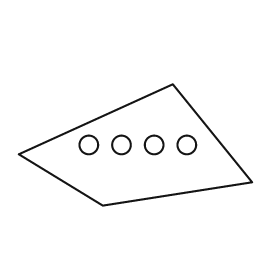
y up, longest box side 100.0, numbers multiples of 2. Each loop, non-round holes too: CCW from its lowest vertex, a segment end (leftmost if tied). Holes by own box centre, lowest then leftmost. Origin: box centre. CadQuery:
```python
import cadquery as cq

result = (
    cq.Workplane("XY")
    .moveTo(-14.0, -26.0)
    .lineTo(50.0, -16.0)
    .lineTo(16.0, 26.0)
    .lineTo(-50.0, -4.0)
    .close()
    .moveTo(-20.0, 0.0)
    .circle(4.0)
    .moveTo(-6.0, 0.0)
    .circle(4.0)
    .moveTo(8.0, 0.0)
    .circle(4.0)
    .moveTo(22.0, 0.0)
    .circle(4.0)
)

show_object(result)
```